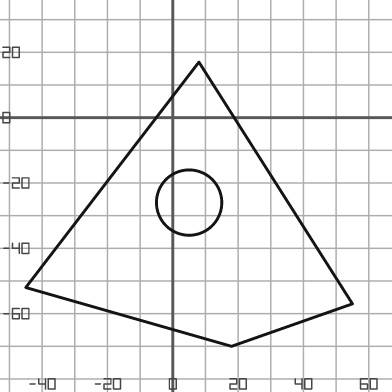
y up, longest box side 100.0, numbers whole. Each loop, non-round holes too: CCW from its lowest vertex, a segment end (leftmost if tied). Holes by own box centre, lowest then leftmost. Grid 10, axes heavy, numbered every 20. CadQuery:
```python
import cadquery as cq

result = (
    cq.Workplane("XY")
    .moveTo(18.0, -70.0)
    .lineTo(55.0, -57.0)
    .lineTo(8.0, 17.0)
    .lineTo(-45.0, -52.0)
    .close()
    .moveTo(5.0, -26.0)
    .circle(10.0)
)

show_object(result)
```